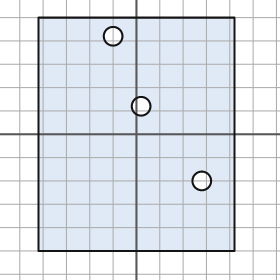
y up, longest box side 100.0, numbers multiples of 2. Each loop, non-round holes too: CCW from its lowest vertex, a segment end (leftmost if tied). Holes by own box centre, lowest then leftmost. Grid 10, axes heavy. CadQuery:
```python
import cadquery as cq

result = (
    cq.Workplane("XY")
    .moveTo(-42.0, -50.0)
    .lineTo(42.0, -50.0)
    .lineTo(42.0, 50.0)
    .lineTo(-42.0, 50.0)
    .close()
    .moveTo(28.0, -20.0)
    .circle(4.0)
    .moveTo(2.0, 12.0)
    .circle(4.0)
    .moveTo(-10.0, 42.0)
    .circle(4.0)
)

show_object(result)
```